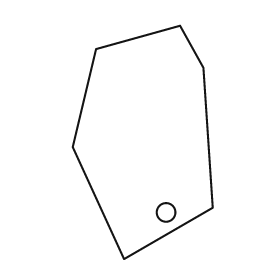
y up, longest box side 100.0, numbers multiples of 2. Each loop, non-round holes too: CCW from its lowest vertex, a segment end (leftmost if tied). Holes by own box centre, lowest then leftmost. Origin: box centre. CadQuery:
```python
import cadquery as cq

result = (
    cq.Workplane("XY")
    .moveTo(-8.0, -50.0)
    .lineTo(30.0, -28.0)
    .lineTo(26.0, 32.0)
    .lineTo(16.0, 50.0)
    .lineTo(-20.0, 40.0)
    .lineTo(-30.0, -2.0)
    .close()
    .moveTo(10.0, -30.0)
    .circle(4.0)
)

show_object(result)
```